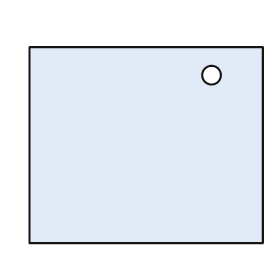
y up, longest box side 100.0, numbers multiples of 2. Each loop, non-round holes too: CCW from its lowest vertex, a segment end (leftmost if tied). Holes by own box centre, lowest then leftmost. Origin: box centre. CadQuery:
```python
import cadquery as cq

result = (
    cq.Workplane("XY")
    .moveTo(-50.0, -42.0)
    .lineTo(50.0, -42.0)
    .lineTo(50.0, 42.0)
    .lineTo(-50.0, 42.0)
    .close()
    .moveTo(28.0, 30.0)
    .circle(4.0)
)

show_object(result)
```